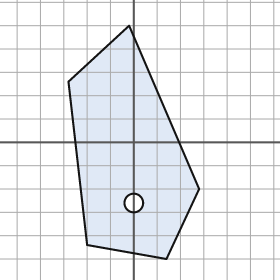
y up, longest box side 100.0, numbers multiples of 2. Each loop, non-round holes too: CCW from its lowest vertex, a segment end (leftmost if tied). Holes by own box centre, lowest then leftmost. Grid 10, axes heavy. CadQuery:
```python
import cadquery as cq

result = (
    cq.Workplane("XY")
    .moveTo(14.0, -50.0)
    .lineTo(28.0, -20.0)
    .lineTo(-2.0, 50.0)
    .lineTo(-28.0, 26.0)
    .lineTo(-20.0, -44.0)
    .close()
    .moveTo(0.0, -26.0)
    .circle(4.0)
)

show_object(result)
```